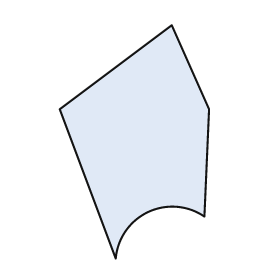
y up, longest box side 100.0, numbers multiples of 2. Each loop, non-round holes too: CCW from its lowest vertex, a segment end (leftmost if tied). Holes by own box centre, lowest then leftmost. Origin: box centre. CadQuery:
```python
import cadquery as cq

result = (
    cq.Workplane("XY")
    .moveTo(-8.0, -50.0)
    .threePointArc((6.0, -30.0), (30.0, -32.0))
    .lineTo(32.0, 14.0)
    .lineTo(16.0, 50.0)
    .lineTo(-32.0, 14.0)
    .close()
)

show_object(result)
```